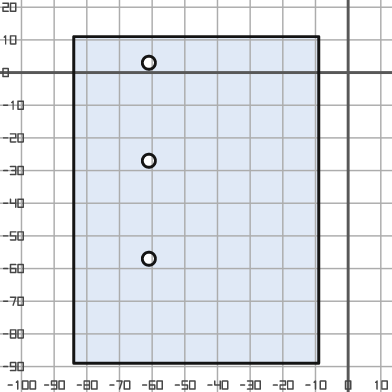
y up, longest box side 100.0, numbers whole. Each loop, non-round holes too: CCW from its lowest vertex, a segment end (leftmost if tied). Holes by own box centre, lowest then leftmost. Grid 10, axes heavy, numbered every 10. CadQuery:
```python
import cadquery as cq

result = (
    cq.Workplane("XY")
    .moveTo(-84.0, -89.0)
    .lineTo(-9.0, -89.0)
    .lineTo(-9.0, 11.0)
    .lineTo(-84.0, 11.0)
    .close()
    .moveTo(-61.0, -57.0)
    .circle(2.0)
    .moveTo(-61.0, -27.0)
    .circle(2.0)
    .moveTo(-61.0, 3.0)
    .circle(2.0)
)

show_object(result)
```